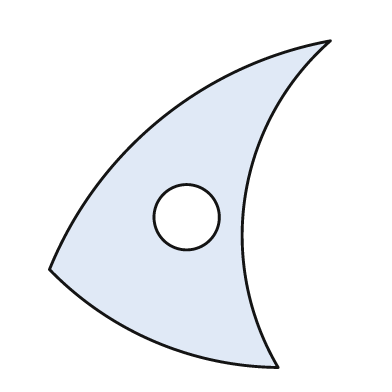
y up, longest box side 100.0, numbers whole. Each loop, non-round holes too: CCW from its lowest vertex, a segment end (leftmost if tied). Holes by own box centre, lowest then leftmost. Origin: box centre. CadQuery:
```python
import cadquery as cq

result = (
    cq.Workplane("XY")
    .moveTo(27.0, -50.0)
    .threePointArc((17.0, 3.0), (43.0, 50.0))
    .threePointArc((-9.0, 26.0), (-43.0, -20.0))
    .threePointArc((-11.0, -42.0), (27.0, -50.0))
    .close()
    .moveTo(-1.0, -4.0)
    .circle(10.0)
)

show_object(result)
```